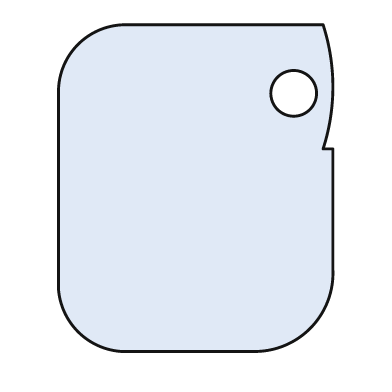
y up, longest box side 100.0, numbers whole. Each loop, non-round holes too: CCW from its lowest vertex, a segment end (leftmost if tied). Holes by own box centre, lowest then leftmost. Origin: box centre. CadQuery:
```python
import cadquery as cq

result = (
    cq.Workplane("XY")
    .moveTo(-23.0, -50.0)
    .lineTo(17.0, -50.0)
    .threePointArc((35.0, -43.0), (42.0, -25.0))
    .lineTo(42.0, 12.0)
    .lineTo(39.0, 12.0)
    .threePointArc((42.0, 31.0), (39.0, 50.0))
    .lineTo(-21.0, 50.0)
    .threePointArc((-36.0, 44.0), (-42.0, 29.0))
    .lineTo(-42.0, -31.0)
    .threePointArc((-36.0, -44.0), (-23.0, -50.0))
    .close()
    .moveTo(30.0, 29.0)
    .circle(7.0)
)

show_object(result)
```